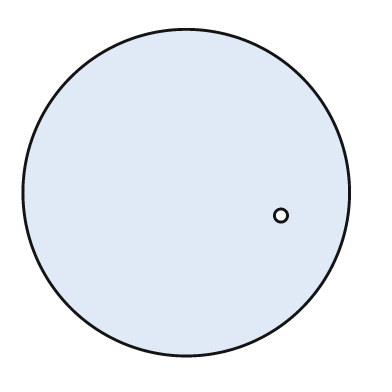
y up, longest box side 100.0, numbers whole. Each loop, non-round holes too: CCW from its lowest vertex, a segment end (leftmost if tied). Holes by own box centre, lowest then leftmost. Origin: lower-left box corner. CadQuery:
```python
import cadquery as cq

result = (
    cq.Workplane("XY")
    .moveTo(50.0, 50.0)
    .circle(50.0)
    .moveTo(79.0, 43.0)
    .circle(2.0)
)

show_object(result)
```